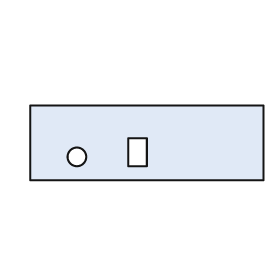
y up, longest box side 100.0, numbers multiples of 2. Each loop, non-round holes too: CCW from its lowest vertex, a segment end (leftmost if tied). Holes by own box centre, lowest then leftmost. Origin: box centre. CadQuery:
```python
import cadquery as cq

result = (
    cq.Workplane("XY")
    .moveTo(-50.0, -16.0)
    .lineTo(50.0, -16.0)
    .lineTo(50.0, 16.0)
    .lineTo(-50.0, 16.0)
    .close()
    .moveTo(-30.0, -6.0)
    .circle(4.0)
    .moveTo(-8.0, -10.0)
    .lineTo(0.0, -10.0)
    .lineTo(0.0, 2.0)
    .lineTo(-8.0, 2.0)
    .close()
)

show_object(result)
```